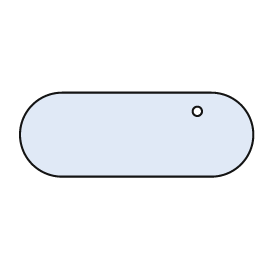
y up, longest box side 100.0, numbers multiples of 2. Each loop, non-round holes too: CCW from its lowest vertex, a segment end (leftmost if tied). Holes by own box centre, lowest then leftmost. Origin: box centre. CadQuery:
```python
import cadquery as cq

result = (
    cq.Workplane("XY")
    .moveTo(-32.0, -18.0)
    .lineTo(32.0, -18.0)
    .threePointArc((50.0, 0.0), (32.0, 18.0))
    .lineTo(-32.0, 18.0)
    .threePointArc((-50.0, 0.0), (-32.0, -18.0))
    .close()
    .moveTo(26.0, 10.0)
    .circle(2.0)
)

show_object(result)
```